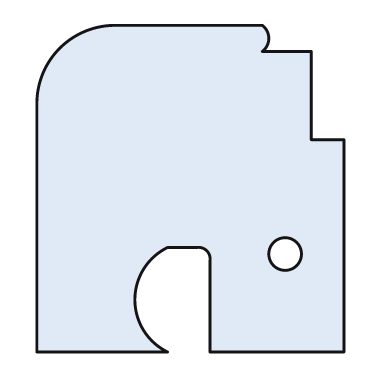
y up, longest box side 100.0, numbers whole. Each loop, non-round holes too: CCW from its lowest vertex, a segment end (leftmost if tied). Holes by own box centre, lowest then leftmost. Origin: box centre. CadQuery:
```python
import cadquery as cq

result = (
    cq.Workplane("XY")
    .moveTo(-47.0, -50.0)
    .lineTo(-7.0, -50.0)
    .threePointArc((-17.0, -34.0), (-7.0, -18.0))
    .lineTo(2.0, -18.0)
    .threePointArc((5.0, -19.0), (6.0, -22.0))
    .lineTo(6.0, -50.0)
    .lineTo(47.0, -50.0)
    .lineTo(47.0, 15.0)
    .lineTo(37.0, 15.0)
    .lineTo(37.0, 42.0)
    .lineTo(22.0, 42.0)
    .threePointArc((24.0, 46.0), (22.0, 50.0))
    .lineTo(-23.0, 50.0)
    .threePointArc((-40.0, 43.0), (-47.0, 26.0))
    .close()
    .moveTo(29.0, -20.0)
    .circle(5.0)
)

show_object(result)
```